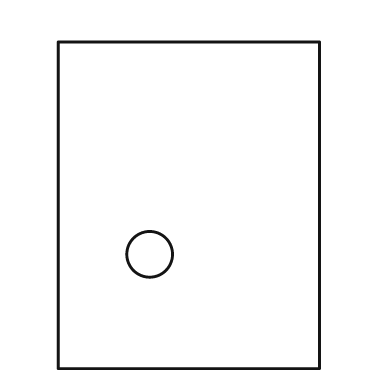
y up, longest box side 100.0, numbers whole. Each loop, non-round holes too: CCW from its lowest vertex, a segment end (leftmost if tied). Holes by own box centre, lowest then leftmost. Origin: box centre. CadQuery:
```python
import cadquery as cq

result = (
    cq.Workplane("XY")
    .moveTo(-40.0, -50.0)
    .lineTo(40.0, -50.0)
    .lineTo(40.0, 50.0)
    .lineTo(-40.0, 50.0)
    .close()
    .moveTo(-12.0, -15.0)
    .circle(7.0)
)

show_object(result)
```